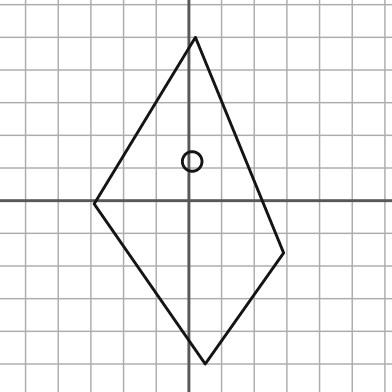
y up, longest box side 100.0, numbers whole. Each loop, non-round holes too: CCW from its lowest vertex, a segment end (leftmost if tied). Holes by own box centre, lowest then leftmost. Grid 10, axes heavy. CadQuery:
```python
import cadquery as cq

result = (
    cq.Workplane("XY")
    .moveTo(5.0, -50.0)
    .lineTo(29.0, -16.0)
    .lineTo(2.0, 50.0)
    .lineTo(-29.0, -1.0)
    .close()
    .moveTo(1.0, 12.0)
    .circle(3.0)
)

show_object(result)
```